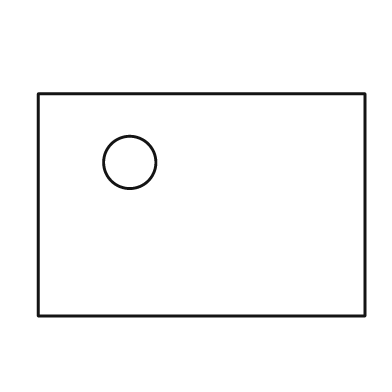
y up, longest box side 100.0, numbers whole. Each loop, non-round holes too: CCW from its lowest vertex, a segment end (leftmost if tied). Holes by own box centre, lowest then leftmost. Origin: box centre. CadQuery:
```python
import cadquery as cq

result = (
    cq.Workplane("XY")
    .moveTo(-50.0, -34.0)
    .lineTo(50.0, -34.0)
    .lineTo(50.0, 34.0)
    .lineTo(-50.0, 34.0)
    .close()
    .moveTo(-22.0, 13.0)
    .circle(8.0)
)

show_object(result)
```